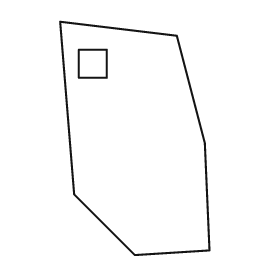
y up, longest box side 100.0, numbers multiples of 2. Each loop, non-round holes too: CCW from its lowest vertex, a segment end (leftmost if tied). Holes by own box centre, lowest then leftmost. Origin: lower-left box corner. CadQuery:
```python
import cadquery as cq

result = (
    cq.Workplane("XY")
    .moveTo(32.0, 0.0)
    .lineTo(64.0, 2.0)
    .lineTo(62.0, 48.0)
    .lineTo(50.0, 94.0)
    .lineTo(0.0, 100.0)
    .lineTo(6.0, 26.0)
    .close()
    .moveTo(8.0, 76.0)
    .lineTo(20.0, 76.0)
    .lineTo(20.0, 88.0)
    .lineTo(8.0, 88.0)
    .close()
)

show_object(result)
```